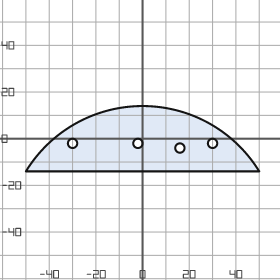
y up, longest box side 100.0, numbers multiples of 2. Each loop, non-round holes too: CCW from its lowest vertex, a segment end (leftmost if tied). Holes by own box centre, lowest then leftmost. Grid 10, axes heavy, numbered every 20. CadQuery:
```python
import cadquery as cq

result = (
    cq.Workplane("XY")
    .moveTo(-50.0, -14.0)
    .lineTo(50.0, -14.0)
    .threePointArc((0.0, 14.0), (-50.0, -14.0))
    .close()
    .moveTo(16.0, -4.0)
    .circle(2.0)
    .moveTo(-30.0, -2.0)
    .circle(2.0)
    .moveTo(-2.0, -2.0)
    .circle(2.0)
    .moveTo(30.0, -2.0)
    .circle(2.0)
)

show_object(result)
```